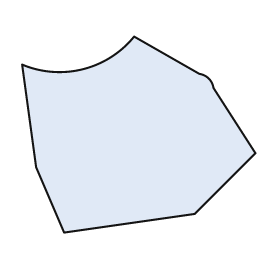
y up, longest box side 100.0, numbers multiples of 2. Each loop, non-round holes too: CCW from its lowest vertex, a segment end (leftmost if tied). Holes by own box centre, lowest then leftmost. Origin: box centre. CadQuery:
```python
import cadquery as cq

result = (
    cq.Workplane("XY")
    .moveTo(-32.0, -42.0)
    .lineTo(24.0, -34.0)
    .lineTo(50.0, -8.0)
    .lineTo(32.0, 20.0)
    .threePointArc((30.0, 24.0), (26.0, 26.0))
    .lineTo(-2.0, 42.0)
    .threePointArc((-24.0, 28.0), (-50.0, 30.0))
    .lineTo(-44.0, -14.0)
    .close()
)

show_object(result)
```